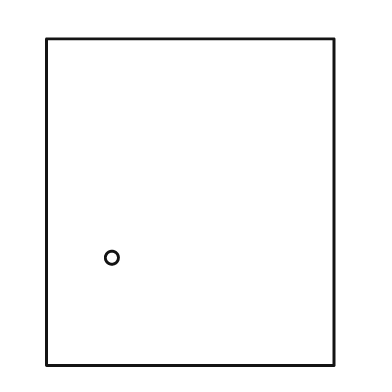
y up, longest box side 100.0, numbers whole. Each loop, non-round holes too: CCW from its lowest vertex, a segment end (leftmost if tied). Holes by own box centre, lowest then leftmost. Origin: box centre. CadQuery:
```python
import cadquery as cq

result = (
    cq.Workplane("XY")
    .moveTo(-44.0, -50.0)
    .lineTo(44.0, -50.0)
    .lineTo(44.0, 50.0)
    .lineTo(-44.0, 50.0)
    .close()
    .moveTo(-24.0, -17.0)
    .circle(2.0)
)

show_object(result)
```